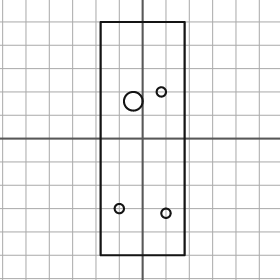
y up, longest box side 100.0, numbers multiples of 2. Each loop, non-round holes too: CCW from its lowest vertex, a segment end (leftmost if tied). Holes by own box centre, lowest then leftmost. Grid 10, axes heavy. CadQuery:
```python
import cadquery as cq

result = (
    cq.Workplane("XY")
    .moveTo(-18.0, -50.0)
    .lineTo(18.0, -50.0)
    .lineTo(18.0, 50.0)
    .lineTo(-18.0, 50.0)
    .close()
    .moveTo(10.0, -32.0)
    .circle(2.0)
    .moveTo(-10.0, -30.0)
    .circle(2.0)
    .moveTo(-4.0, 16.0)
    .circle(4.0)
    .moveTo(8.0, 20.0)
    .circle(2.0)
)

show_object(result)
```